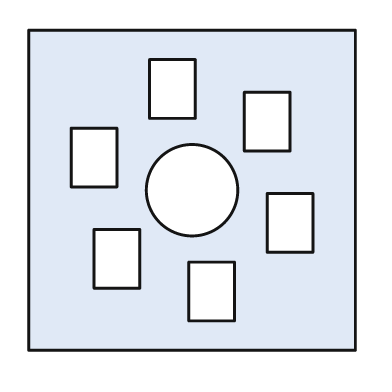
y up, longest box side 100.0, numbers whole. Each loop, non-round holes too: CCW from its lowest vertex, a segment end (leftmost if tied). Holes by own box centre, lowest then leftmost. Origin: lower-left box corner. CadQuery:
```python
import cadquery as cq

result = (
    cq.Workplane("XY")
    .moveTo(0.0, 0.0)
    .lineTo(100.0, 0.0)
    .lineTo(100.0, 98.0)
    .lineTo(0.0, 98.0)
    .close()
    .moveTo(49.0, 9.0)
    .lineTo(63.0, 9.0)
    .lineTo(63.0, 27.0)
    .lineTo(49.0, 27.0)
    .close()
    .moveTo(20.0, 19.0)
    .lineTo(34.0, 19.0)
    .lineTo(34.0, 37.0)
    .lineTo(20.0, 37.0)
    .close()
    .moveTo(73.0, 30.0)
    .lineTo(87.0, 30.0)
    .lineTo(87.0, 48.0)
    .lineTo(73.0, 48.0)
    .close()
    .moveTo(50.0, 49.0)
    .circle(14.0)
    .moveTo(13.0, 50.0)
    .lineTo(27.0, 50.0)
    .lineTo(27.0, 68.0)
    .lineTo(13.0, 68.0)
    .close()
    .moveTo(66.0, 61.0)
    .lineTo(80.0, 61.0)
    .lineTo(80.0, 79.0)
    .lineTo(66.0, 79.0)
    .close()
    .moveTo(37.0, 71.0)
    .lineTo(51.0, 71.0)
    .lineTo(51.0, 89.0)
    .lineTo(37.0, 89.0)
    .close()
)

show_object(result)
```